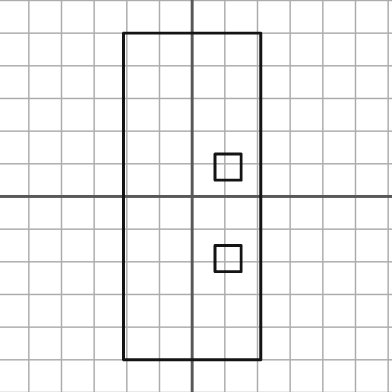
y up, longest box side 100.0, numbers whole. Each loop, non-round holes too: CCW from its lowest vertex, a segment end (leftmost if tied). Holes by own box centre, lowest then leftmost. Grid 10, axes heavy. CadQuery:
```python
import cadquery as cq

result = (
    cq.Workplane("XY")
    .moveTo(-21.0, -50.0)
    .lineTo(21.0, -50.0)
    .lineTo(21.0, 50.0)
    .lineTo(-21.0, 50.0)
    .close()
    .moveTo(7.0, -23.0)
    .lineTo(15.0, -23.0)
    .lineTo(15.0, -15.0)
    .lineTo(7.0, -15.0)
    .close()
    .moveTo(7.0, 5.0)
    .lineTo(15.0, 5.0)
    .lineTo(15.0, 13.0)
    .lineTo(7.0, 13.0)
    .close()
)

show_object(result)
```